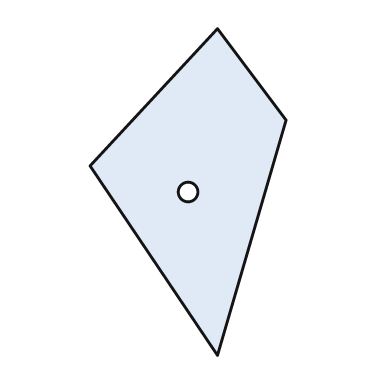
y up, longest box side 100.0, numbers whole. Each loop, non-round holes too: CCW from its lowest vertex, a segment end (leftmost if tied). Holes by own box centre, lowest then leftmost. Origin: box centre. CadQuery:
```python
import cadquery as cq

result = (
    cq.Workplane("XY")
    .moveTo(9.0, -50.0)
    .lineTo(30.0, 22.0)
    .lineTo(9.0, 50.0)
    .lineTo(-30.0, 8.0)
    .close()
    .moveTo(0.0, 0.0)
    .circle(3.0)
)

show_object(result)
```